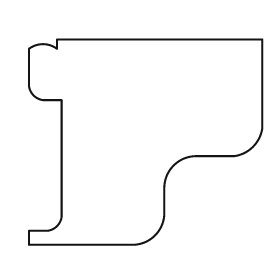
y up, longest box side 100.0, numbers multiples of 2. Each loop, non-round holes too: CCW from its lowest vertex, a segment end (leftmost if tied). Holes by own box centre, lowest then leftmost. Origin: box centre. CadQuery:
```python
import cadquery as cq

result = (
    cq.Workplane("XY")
    .moveTo(-50.0, -44.0)
    .lineTo(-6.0, -44.0)
    .threePointArc((4.0, -40.0), (8.0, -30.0))
    .lineTo(8.0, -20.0)
    .threePointArc((12.0, -10.0), (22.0, -6.0))
    .lineTo(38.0, -6.0)
    .threePointArc((46.0, -2.0), (50.0, 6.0))
    .lineTo(50.0, 44.0)
    .lineTo(-38.0, 44.0)
    .lineTo(-38.0, 40.0)
    .threePointArc((-44.0, 42.0), (-50.0, 40.0))
    .lineTo(-50.0, 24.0)
    .threePointArc((-48.0, 20.0), (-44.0, 18.0))
    .lineTo(-36.0, 18.0)
    .lineTo(-36.0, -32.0)
    .threePointArc((-38.0, -36.0), (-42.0, -38.0))
    .lineTo(-50.0, -38.0)
    .close()
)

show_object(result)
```